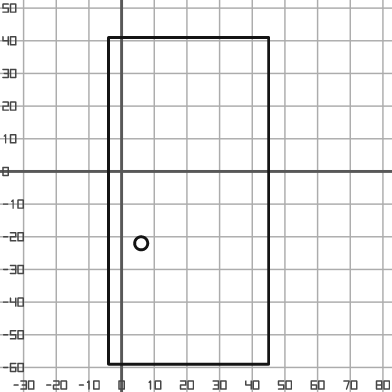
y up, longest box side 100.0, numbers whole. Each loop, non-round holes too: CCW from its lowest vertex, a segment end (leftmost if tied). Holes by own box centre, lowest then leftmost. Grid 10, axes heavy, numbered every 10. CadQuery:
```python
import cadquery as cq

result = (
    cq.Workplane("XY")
    .moveTo(-4.0, -59.0)
    .lineTo(45.0, -59.0)
    .lineTo(45.0, 41.0)
    .lineTo(-4.0, 41.0)
    .close()
    .moveTo(6.0, -22.0)
    .circle(2.0)
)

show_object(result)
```